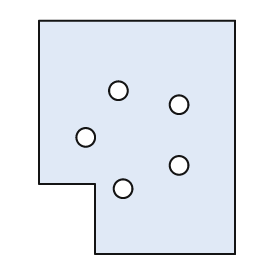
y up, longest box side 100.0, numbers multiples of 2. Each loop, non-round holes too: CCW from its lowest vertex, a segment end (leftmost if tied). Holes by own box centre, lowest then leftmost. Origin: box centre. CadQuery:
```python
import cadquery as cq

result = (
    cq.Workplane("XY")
    .moveTo(-18.0, -50.0)
    .lineTo(42.0, -50.0)
    .lineTo(42.0, 50.0)
    .lineTo(-42.0, 50.0)
    .lineTo(-42.0, -20.0)
    .lineTo(-18.0, -20.0)
    .close()
    .moveTo(-6.0, -22.0)
    .circle(4.0)
    .moveTo(18.0, -12.0)
    .circle(4.0)
    .moveTo(-22.0, 0.0)
    .circle(4.0)
    .moveTo(18.0, 14.0)
    .circle(4.0)
    .moveTo(-8.0, 20.0)
    .circle(4.0)
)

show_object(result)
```